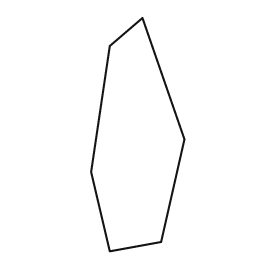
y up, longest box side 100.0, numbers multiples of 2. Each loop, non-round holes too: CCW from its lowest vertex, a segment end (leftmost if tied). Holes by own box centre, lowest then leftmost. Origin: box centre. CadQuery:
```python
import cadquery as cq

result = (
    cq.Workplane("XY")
    .moveTo(-12.0, -50.0)
    .lineTo(10.0, -46.0)
    .lineTo(20.0, -2.0)
    .lineTo(2.0, 50.0)
    .lineTo(-12.0, 38.0)
    .lineTo(-20.0, -16.0)
    .close()
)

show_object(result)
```